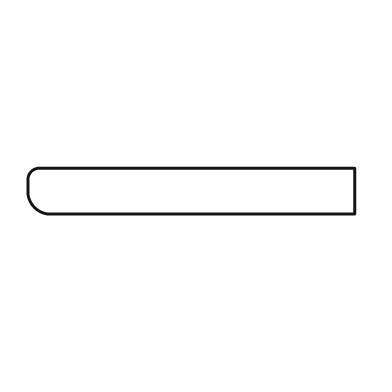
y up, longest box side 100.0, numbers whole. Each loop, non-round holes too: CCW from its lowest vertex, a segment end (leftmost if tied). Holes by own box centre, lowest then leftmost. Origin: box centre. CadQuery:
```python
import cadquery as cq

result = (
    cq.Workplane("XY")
    .moveTo(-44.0, -7.0)
    .lineTo(50.0, -7.0)
    .lineTo(50.0, 7.0)
    .lineTo(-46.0, 7.0)
    .threePointArc((-49.0, 6.0), (-50.0, 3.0))
    .lineTo(-50.0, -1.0)
    .threePointArc((-48.0, -5.0), (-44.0, -7.0))
    .close()
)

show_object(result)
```